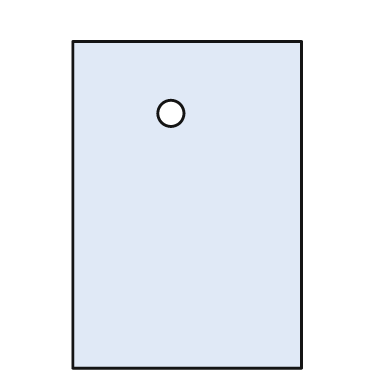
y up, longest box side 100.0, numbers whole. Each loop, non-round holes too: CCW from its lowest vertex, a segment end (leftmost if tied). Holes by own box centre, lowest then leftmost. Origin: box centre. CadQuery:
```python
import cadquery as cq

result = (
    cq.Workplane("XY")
    .moveTo(-35.0, -50.0)
    .lineTo(35.0, -50.0)
    .lineTo(35.0, 50.0)
    .lineTo(-35.0, 50.0)
    .close()
    .moveTo(-5.0, 28.0)
    .circle(4.0)
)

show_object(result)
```